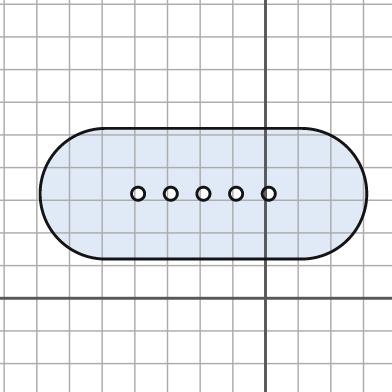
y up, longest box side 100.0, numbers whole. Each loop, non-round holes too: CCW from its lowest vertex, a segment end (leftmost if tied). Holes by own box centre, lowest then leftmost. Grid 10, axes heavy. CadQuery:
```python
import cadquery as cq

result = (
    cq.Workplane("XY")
    .moveTo(-49.0, 12.0)
    .lineTo(11.0, 12.0)
    .threePointArc((31.0, 32.0), (11.0, 52.0))
    .lineTo(-49.0, 52.0)
    .threePointArc((-69.0, 32.0), (-49.0, 12.0))
    .close()
    .moveTo(-39.0, 32.0)
    .circle(2.0)
    .moveTo(-29.0, 32.0)
    .circle(2.0)
    .moveTo(-19.0, 32.0)
    .circle(2.0)
    .moveTo(-9.0, 32.0)
    .circle(2.0)
    .moveTo(1.0, 32.0)
    .circle(2.0)
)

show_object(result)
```